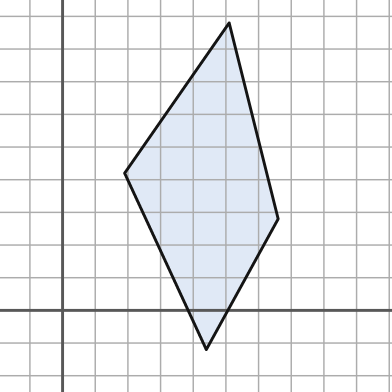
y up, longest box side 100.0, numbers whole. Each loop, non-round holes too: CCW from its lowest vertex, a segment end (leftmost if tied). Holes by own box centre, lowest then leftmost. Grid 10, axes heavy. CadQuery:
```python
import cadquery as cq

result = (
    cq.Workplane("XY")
    .moveTo(44.0, -12.0)
    .lineTo(66.0, 28.0)
    .lineTo(51.0, 88.0)
    .lineTo(19.0, 42.0)
    .close()
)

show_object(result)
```